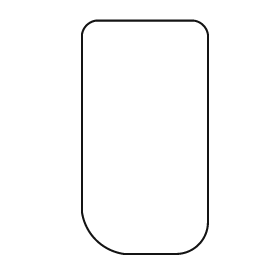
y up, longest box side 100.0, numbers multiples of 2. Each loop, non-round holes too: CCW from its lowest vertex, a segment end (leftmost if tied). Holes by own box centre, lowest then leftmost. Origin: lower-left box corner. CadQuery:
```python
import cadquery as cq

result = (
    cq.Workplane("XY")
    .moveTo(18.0, 0.0)
    .lineTo(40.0, 0.0)
    .threePointArc((50.0, 4.0), (54.0, 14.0))
    .lineTo(54.0, 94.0)
    .threePointArc((52.0, 98.0), (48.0, 100.0))
    .lineTo(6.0, 100.0)
    .threePointArc((2.0, 98.0), (0.0, 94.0))
    .lineTo(0.0, 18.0)
    .threePointArc((6.0, 6.0), (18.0, 0.0))
    .close()
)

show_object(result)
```